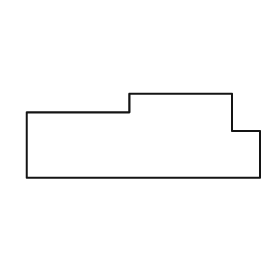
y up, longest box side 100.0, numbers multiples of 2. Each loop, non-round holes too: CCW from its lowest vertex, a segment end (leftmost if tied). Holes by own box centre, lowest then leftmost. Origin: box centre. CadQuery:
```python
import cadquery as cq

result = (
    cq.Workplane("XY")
    .moveTo(-50.0, -18.0)
    .lineTo(50.0, -18.0)
    .lineTo(50.0, 2.0)
    .lineTo(38.0, 2.0)
    .lineTo(38.0, 18.0)
    .lineTo(-6.0, 18.0)
    .lineTo(-6.0, 10.0)
    .lineTo(-50.0, 10.0)
    .close()
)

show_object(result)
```